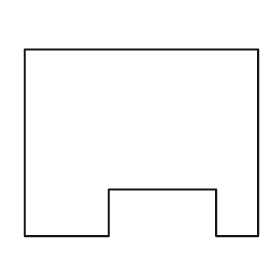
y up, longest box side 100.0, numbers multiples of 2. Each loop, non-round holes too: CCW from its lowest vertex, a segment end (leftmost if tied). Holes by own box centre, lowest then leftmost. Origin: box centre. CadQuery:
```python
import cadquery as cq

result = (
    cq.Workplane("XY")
    .moveTo(-50.0, -40.0)
    .lineTo(-14.0, -40.0)
    .lineTo(-14.0, -20.0)
    .lineTo(32.0, -20.0)
    .lineTo(32.0, -40.0)
    .lineTo(50.0, -40.0)
    .lineTo(50.0, 40.0)
    .lineTo(-50.0, 40.0)
    .close()
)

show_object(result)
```